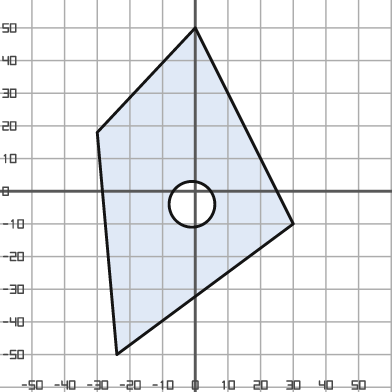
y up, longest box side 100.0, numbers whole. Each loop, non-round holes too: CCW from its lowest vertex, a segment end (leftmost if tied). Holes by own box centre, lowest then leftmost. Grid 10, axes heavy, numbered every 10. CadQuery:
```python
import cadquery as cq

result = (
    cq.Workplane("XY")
    .moveTo(-24.0, -50.0)
    .lineTo(30.0, -10.0)
    .lineTo(0.0, 50.0)
    .lineTo(-30.0, 18.0)
    .close()
    .moveTo(-1.0, -4.0)
    .circle(7.0)
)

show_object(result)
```